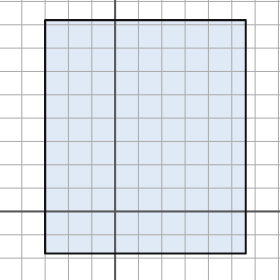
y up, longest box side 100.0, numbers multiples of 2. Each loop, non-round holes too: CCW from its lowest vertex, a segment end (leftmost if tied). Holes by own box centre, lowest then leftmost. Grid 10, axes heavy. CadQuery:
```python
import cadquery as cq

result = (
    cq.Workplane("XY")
    .moveTo(-30.0, -18.0)
    .lineTo(56.0, -18.0)
    .lineTo(56.0, 82.0)
    .lineTo(-30.0, 82.0)
    .close()
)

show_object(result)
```